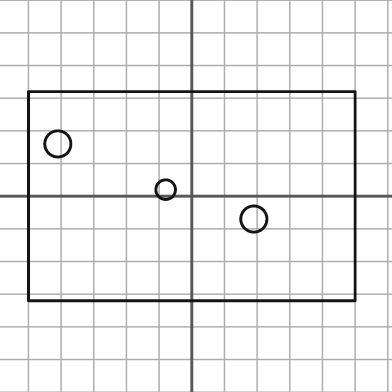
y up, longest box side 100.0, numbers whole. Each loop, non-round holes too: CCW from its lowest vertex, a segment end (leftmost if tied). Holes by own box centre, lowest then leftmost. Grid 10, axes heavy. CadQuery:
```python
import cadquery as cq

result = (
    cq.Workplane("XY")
    .moveTo(-50.0, -32.0)
    .lineTo(50.0, -32.0)
    .lineTo(50.0, 32.0)
    .lineTo(-50.0, 32.0)
    .close()
    .moveTo(19.0, -7.0)
    .circle(4.0)
    .moveTo(-8.0, 2.0)
    .circle(3.0)
    .moveTo(-41.0, 16.0)
    .circle(4.0)
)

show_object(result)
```